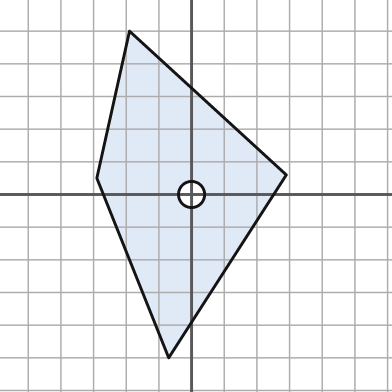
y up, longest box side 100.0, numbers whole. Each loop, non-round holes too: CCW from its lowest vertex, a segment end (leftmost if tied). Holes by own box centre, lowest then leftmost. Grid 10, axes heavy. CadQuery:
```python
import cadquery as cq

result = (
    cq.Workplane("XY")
    .moveTo(-7.0, -50.0)
    .lineTo(29.0, 6.0)
    .lineTo(-19.0, 50.0)
    .lineTo(-29.0, 5.0)
    .close()
    .moveTo(0.0, 0.0)
    .circle(4.0)
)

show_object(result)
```